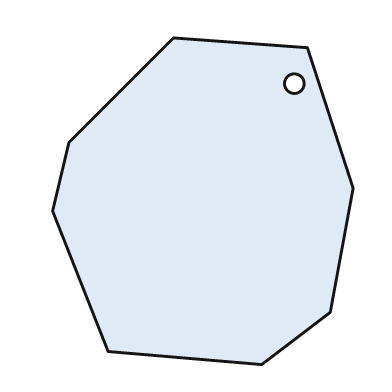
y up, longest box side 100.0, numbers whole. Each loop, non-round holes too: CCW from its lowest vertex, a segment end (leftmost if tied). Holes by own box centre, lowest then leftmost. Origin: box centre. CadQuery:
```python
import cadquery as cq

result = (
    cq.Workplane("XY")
    .moveTo(18.0, -50.0)
    .lineTo(39.0, -34.0)
    .lineTo(46.0, 4.0)
    .lineTo(32.0, 47.0)
    .lineTo(-9.0, 50.0)
    .lineTo(-41.0, 18.0)
    .lineTo(-46.0, -3.0)
    .lineTo(-29.0, -46.0)
    .close()
    .moveTo(28.0, 36.0)
    .circle(3.0)
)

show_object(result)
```